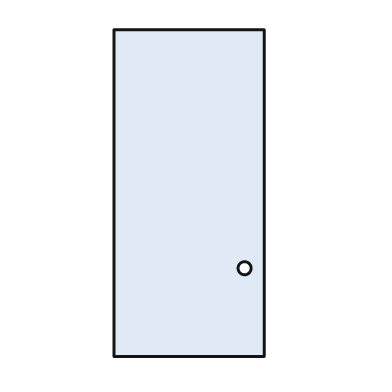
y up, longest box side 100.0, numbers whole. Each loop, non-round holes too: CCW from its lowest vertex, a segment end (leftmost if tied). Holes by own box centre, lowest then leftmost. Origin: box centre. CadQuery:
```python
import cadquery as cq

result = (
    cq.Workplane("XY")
    .moveTo(-23.0, -50.0)
    .lineTo(23.0, -50.0)
    .lineTo(23.0, 50.0)
    .lineTo(-23.0, 50.0)
    .close()
    .moveTo(17.0, -23.0)
    .circle(2.0)
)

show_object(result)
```